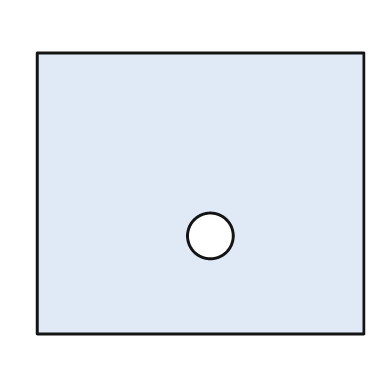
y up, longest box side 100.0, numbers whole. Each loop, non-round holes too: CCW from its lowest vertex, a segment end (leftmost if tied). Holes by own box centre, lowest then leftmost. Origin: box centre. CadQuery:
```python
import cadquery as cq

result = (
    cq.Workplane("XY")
    .moveTo(-50.0, -43.0)
    .lineTo(50.0, -43.0)
    .lineTo(50.0, 43.0)
    .lineTo(-50.0, 43.0)
    .close()
    .moveTo(3.0, -13.0)
    .circle(7.0)
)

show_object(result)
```